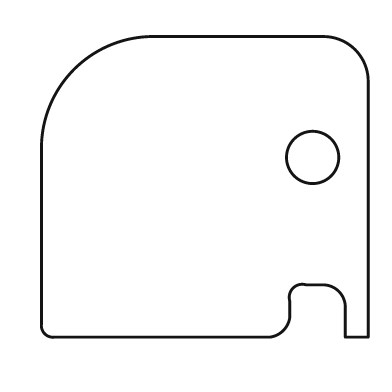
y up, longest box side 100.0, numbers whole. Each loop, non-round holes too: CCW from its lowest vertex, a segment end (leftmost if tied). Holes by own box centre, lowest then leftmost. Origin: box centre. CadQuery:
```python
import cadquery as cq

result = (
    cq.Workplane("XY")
    .moveTo(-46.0, -46.0)
    .lineTo(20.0, -46.0)
    .threePointArc((24.0, -44.0), (26.0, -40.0))
    .lineTo(26.0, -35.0)
    .threePointArc((27.0, -31.0), (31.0, -30.0))
    .lineTo(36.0, -30.0)
    .threePointArc((41.0, -32.0), (43.0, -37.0))
    .lineTo(43.0, -46.0)
    .lineTo(50.0, -46.0)
    .lineTo(50.0, 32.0)
    .threePointArc((46.0, 42.0), (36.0, 46.0))
    .lineTo(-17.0, 46.0)
    .threePointArc((-40.0, 36.0), (-50.0, 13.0))
    .lineTo(-50.0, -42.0)
    .threePointArc((-49.0, -45.0), (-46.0, -46.0))
    .close()
    .moveTo(33.0, 9.0)
    .circle(8.0)
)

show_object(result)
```